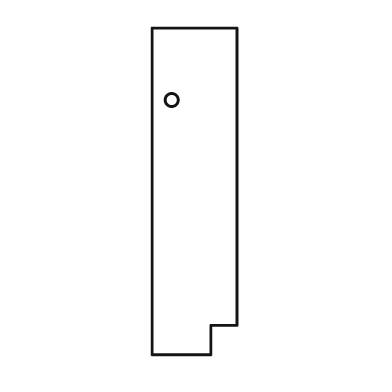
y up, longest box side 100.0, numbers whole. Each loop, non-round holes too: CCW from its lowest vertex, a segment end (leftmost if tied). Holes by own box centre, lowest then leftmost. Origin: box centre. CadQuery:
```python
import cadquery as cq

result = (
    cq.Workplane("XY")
    .moveTo(-13.0, -50.0)
    .lineTo(5.0, -50.0)
    .lineTo(5.0, -41.0)
    .lineTo(13.0, -41.0)
    .lineTo(13.0, 50.0)
    .lineTo(-13.0, 50.0)
    .close()
    .moveTo(-7.0, 28.0)
    .circle(2.0)
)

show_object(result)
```